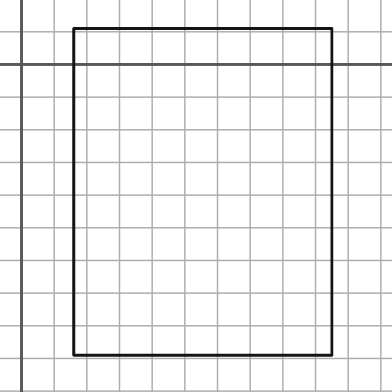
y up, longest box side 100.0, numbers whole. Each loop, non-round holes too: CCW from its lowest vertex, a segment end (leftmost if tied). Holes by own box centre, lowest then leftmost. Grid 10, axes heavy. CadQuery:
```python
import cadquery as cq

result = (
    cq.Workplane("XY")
    .moveTo(16.0, -89.0)
    .lineTo(95.0, -89.0)
    .lineTo(95.0, 11.0)
    .lineTo(16.0, 11.0)
    .close()
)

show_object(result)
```